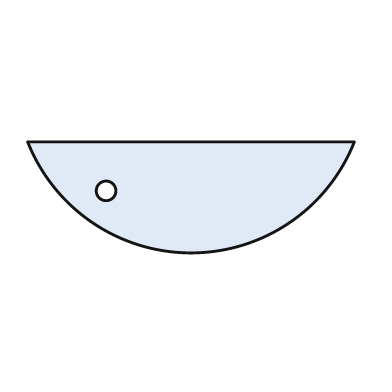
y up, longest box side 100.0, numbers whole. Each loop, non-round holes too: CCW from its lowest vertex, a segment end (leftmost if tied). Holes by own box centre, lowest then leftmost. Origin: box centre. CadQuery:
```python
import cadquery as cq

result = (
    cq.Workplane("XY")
    .moveTo(-50.0, 17.0)
    .threePointArc((0.0, -17.0), (50.0, 17.0))
    .close()
    .moveTo(-26.0, 2.0)
    .circle(3.0)
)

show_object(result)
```